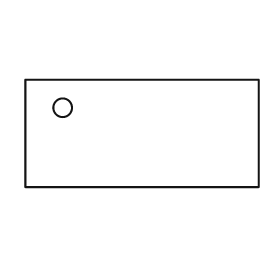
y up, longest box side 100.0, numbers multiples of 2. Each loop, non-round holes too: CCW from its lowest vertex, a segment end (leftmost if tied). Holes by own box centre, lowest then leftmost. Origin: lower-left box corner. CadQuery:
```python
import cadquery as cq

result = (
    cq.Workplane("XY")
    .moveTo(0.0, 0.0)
    .lineTo(100.0, 0.0)
    .lineTo(100.0, 46.0)
    .lineTo(0.0, 46.0)
    .close()
    .moveTo(16.0, 34.0)
    .circle(4.0)
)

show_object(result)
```